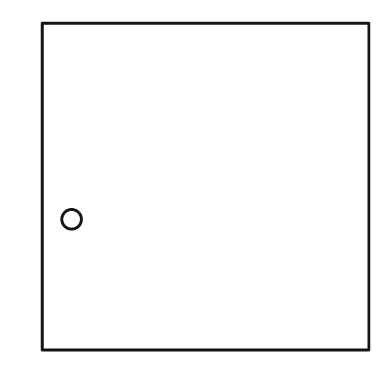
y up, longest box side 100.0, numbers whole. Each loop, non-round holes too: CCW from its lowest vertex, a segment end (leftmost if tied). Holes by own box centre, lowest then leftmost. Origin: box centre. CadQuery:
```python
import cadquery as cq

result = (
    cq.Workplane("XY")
    .moveTo(-50.0, -50.0)
    .lineTo(50.0, -50.0)
    .lineTo(50.0, 50.0)
    .lineTo(-50.0, 50.0)
    .close()
    .moveTo(-41.0, -10.0)
    .circle(3.0)
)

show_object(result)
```